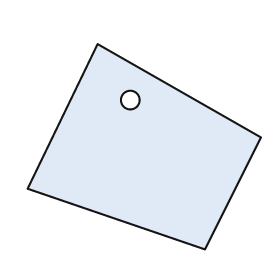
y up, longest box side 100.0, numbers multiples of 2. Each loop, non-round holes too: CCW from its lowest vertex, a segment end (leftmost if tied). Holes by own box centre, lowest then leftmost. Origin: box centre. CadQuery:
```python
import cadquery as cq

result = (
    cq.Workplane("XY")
    .moveTo(26.0, -44.0)
    .lineTo(50.0, 4.0)
    .lineTo(-20.0, 44.0)
    .lineTo(-50.0, -18.0)
    .close()
    .moveTo(-6.0, 20.0)
    .circle(4.0)
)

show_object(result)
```